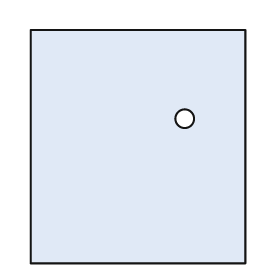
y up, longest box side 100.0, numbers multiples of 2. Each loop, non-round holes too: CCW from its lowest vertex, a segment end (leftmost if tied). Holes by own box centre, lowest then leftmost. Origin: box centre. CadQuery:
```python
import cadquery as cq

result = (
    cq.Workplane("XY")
    .moveTo(-46.0, -50.0)
    .lineTo(46.0, -50.0)
    .lineTo(46.0, 50.0)
    .lineTo(-46.0, 50.0)
    .close()
    .moveTo(20.0, 12.0)
    .circle(4.0)
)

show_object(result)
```